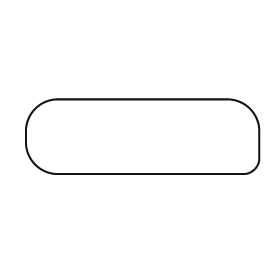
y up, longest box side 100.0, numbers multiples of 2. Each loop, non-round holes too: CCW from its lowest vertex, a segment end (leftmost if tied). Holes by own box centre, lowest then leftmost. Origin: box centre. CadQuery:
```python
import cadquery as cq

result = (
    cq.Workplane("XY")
    .moveTo(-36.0, -16.0)
    .lineTo(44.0, -16.0)
    .threePointArc((48.0, -14.0), (50.0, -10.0))
    .lineTo(50.0, 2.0)
    .threePointArc((46.0, 12.0), (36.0, 16.0))
    .lineTo(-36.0, 16.0)
    .threePointArc((-46.0, 12.0), (-50.0, 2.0))
    .lineTo(-50.0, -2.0)
    .threePointArc((-46.0, -12.0), (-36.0, -16.0))
    .close()
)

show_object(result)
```